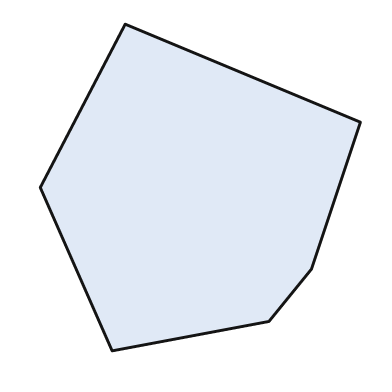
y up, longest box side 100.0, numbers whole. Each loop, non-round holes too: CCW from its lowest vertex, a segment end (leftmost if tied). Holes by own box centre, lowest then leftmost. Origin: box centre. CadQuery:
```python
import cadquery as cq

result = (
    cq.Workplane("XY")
    .moveTo(-27.0, -50.0)
    .lineTo(21.0, -41.0)
    .lineTo(34.0, -25.0)
    .lineTo(49.0, 20.0)
    .lineTo(-23.0, 50.0)
    .lineTo(-49.0, 0.0)
    .close()
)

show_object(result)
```